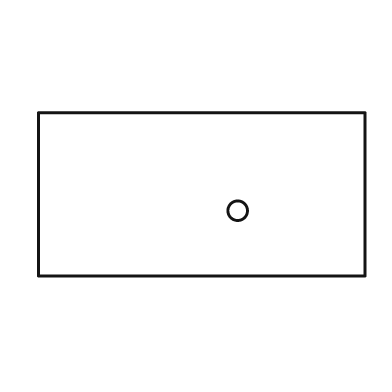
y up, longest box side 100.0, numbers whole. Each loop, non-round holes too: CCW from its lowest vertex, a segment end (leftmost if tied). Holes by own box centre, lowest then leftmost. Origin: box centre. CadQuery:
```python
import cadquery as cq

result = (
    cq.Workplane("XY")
    .moveTo(-50.0, -25.0)
    .lineTo(50.0, -25.0)
    .lineTo(50.0, 25.0)
    .lineTo(-50.0, 25.0)
    .close()
    .moveTo(11.0, -5.0)
    .circle(3.0)
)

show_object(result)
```